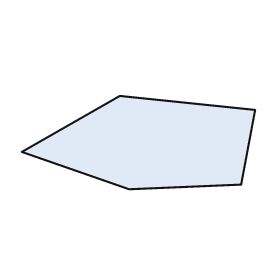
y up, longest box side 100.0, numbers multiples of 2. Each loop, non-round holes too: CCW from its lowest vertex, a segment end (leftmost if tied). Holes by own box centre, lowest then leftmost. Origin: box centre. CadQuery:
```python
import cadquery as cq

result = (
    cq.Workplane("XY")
    .moveTo(-4.0, -20.0)
    .lineTo(44.0, -18.0)
    .lineTo(50.0, 14.0)
    .lineTo(-8.0, 20.0)
    .lineTo(-50.0, -4.0)
    .close()
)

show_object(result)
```